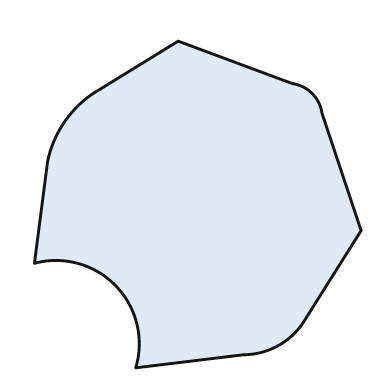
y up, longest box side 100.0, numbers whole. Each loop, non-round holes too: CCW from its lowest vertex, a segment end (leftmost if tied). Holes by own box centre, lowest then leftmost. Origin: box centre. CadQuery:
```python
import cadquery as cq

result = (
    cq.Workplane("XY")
    .moveTo(-19.0, -50.0)
    .lineTo(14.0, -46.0)
    .threePointArc((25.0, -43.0), (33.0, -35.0))
    .lineTo(50.0, -8.0)
    .lineTo(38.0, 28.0)
    .threePointArc((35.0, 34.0), (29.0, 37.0))
    .lineTo(-6.0, 50.0)
    .lineTo(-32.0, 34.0)
    .threePointArc((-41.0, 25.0), (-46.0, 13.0))
    .lineTo(-50.0, -18.0)
    .threePointArc((-25.0, -25.0), (-19.0, -50.0))
    .close()
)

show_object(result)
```